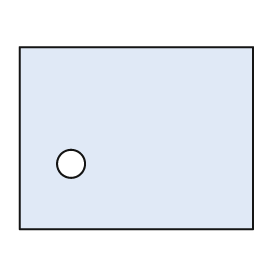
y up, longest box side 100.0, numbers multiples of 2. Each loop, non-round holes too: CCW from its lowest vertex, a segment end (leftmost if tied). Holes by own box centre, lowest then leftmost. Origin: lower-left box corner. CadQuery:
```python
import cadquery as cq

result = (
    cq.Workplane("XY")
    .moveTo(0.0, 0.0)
    .lineTo(100.0, 0.0)
    .lineTo(100.0, 78.0)
    .lineTo(0.0, 78.0)
    .close()
    .moveTo(22.0, 28.0)
    .circle(6.0)
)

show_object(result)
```